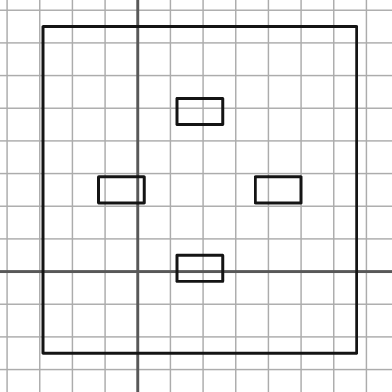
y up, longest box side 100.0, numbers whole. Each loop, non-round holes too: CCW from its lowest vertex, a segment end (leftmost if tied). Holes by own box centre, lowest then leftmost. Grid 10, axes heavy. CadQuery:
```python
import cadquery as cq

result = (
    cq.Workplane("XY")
    .moveTo(-29.0, -25.0)
    .lineTo(67.0, -25.0)
    .lineTo(67.0, 75.0)
    .lineTo(-29.0, 75.0)
    .close()
    .moveTo(12.0, -3.0)
    .lineTo(26.0, -3.0)
    .lineTo(26.0, 5.0)
    .lineTo(12.0, 5.0)
    .close()
    .moveTo(-12.0, 21.0)
    .lineTo(2.0, 21.0)
    .lineTo(2.0, 29.0)
    .lineTo(-12.0, 29.0)
    .close()
    .moveTo(36.0, 21.0)
    .lineTo(50.0, 21.0)
    .lineTo(50.0, 29.0)
    .lineTo(36.0, 29.0)
    .close()
    .moveTo(12.0, 45.0)
    .lineTo(26.0, 45.0)
    .lineTo(26.0, 53.0)
    .lineTo(12.0, 53.0)
    .close()
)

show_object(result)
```